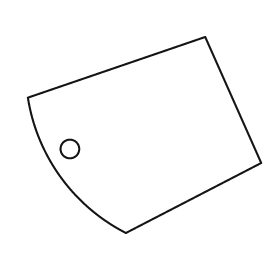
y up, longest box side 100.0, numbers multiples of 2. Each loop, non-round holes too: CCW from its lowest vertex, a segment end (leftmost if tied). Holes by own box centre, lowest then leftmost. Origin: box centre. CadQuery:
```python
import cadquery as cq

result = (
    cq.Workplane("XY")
    .moveTo(-8.0, -42.0)
    .lineTo(50.0, -12.0)
    .lineTo(26.0, 42.0)
    .lineTo(-50.0, 16.0)
    .threePointArc((-36.0, -18.0), (-8.0, -42.0))
    .close()
    .moveTo(-32.0, -6.0)
    .circle(4.0)
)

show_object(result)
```